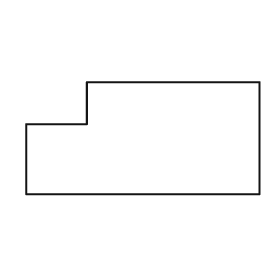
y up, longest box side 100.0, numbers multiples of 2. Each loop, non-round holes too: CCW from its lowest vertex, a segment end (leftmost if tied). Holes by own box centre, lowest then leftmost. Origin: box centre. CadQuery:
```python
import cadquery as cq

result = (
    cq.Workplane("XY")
    .moveTo(-50.0, -24.0)
    .lineTo(50.0, -24.0)
    .lineTo(50.0, 24.0)
    .lineTo(-24.0, 24.0)
    .lineTo(-24.0, 6.0)
    .lineTo(-50.0, 6.0)
    .close()
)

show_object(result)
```